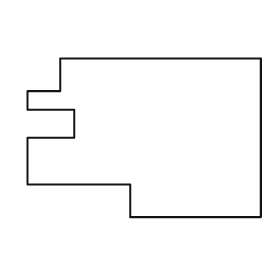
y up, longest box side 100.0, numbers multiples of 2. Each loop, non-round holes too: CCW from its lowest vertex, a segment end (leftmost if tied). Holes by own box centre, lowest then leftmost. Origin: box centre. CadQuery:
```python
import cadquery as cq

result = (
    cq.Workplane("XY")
    .moveTo(-6.0, -34.0)
    .lineTo(50.0, -34.0)
    .lineTo(50.0, 34.0)
    .lineTo(-36.0, 34.0)
    .lineTo(-36.0, 20.0)
    .lineTo(-50.0, 20.0)
    .lineTo(-50.0, 12.0)
    .lineTo(-30.0, 12.0)
    .lineTo(-30.0, 0.0)
    .lineTo(-50.0, 0.0)
    .lineTo(-50.0, -20.0)
    .lineTo(-6.0, -20.0)
    .close()
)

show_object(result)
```